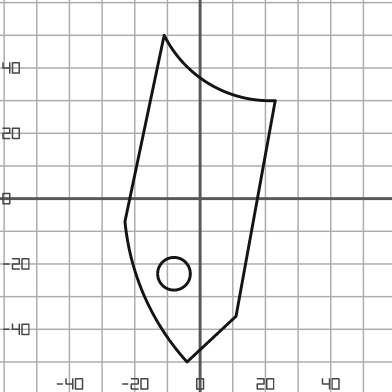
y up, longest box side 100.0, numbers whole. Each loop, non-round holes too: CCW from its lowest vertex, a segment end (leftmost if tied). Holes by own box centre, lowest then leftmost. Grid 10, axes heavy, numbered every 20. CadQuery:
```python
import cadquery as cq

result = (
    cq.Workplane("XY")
    .moveTo(-4.0, -50.0)
    .lineTo(11.0, -36.0)
    .lineTo(23.0, 30.0)
    .threePointArc((3.0, 35.0), (-11.0, 50.0))
    .lineTo(-23.0, -7.0)
    .threePointArc((-17.0, -30.0), (-4.0, -50.0))
    .close()
    .moveTo(-8.0, -23.0)
    .circle(5.0)
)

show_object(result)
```